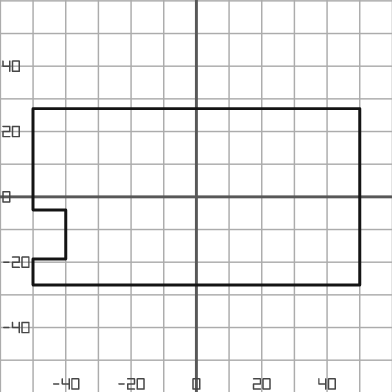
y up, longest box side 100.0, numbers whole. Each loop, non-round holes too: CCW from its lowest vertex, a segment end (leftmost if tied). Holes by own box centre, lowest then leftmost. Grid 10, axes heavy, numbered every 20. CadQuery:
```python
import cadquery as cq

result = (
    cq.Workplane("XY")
    .moveTo(-50.0, -27.0)
    .lineTo(50.0, -27.0)
    .lineTo(50.0, 27.0)
    .lineTo(-50.0, 27.0)
    .lineTo(-50.0, -4.0)
    .lineTo(-40.0, -4.0)
    .lineTo(-40.0, -19.0)
    .lineTo(-50.0, -19.0)
    .close()
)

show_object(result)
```